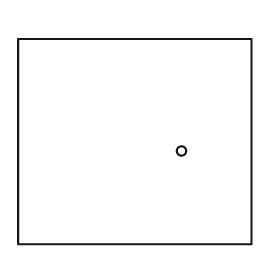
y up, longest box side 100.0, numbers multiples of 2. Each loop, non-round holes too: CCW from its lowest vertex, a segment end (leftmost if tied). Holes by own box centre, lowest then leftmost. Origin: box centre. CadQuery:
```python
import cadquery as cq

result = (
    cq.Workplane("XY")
    .moveTo(-50.0, -44.0)
    .lineTo(50.0, -44.0)
    .lineTo(50.0, 44.0)
    .lineTo(-50.0, 44.0)
    .close()
    .moveTo(20.0, -4.0)
    .circle(2.0)
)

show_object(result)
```